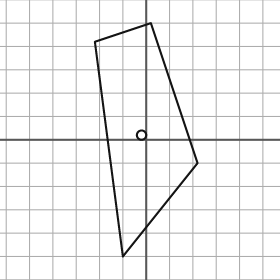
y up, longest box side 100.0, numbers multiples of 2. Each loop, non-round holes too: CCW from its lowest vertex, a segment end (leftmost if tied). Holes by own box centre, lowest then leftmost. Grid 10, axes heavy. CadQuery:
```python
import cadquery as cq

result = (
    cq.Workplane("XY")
    .moveTo(-10.0, -50.0)
    .lineTo(22.0, -10.0)
    .lineTo(2.0, 50.0)
    .lineTo(-22.0, 42.0)
    .close()
    .moveTo(-2.0, 2.0)
    .circle(2.0)
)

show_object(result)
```